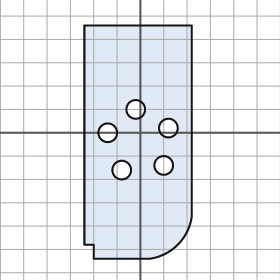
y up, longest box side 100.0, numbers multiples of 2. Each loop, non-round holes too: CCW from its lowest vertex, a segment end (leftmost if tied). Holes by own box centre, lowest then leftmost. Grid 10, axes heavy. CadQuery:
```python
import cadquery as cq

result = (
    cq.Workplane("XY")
    .moveTo(-20.0, -54.0)
    .lineTo(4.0, -54.0)
    .threePointArc((16.0, -48.0), (22.0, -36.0))
    .lineTo(22.0, 46.0)
    .lineTo(-24.0, 46.0)
    .lineTo(-24.0, -48.0)
    .lineTo(-20.0, -48.0)
    .close()
    .moveTo(-8.0, -16.0)
    .circle(4.0)
    .moveTo(10.0, -14.0)
    .circle(4.0)
    .moveTo(-14.0, 0.0)
    .circle(4.0)
    .moveTo(12.0, 2.0)
    .circle(4.0)
    .moveTo(-2.0, 10.0)
    .circle(4.0)
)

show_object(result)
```